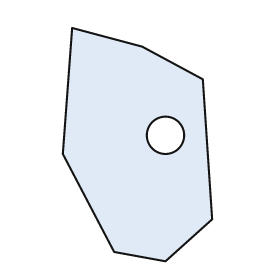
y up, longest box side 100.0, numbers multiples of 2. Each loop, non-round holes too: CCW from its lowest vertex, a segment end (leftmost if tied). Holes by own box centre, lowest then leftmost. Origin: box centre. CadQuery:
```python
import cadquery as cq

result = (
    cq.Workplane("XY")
    .moveTo(12.0, -50.0)
    .lineTo(32.0, -32.0)
    .lineTo(28.0, 28.0)
    .lineTo(2.0, 42.0)
    .lineTo(-28.0, 50.0)
    .lineTo(-32.0, -4.0)
    .lineTo(-10.0, -46.0)
    .close()
    .moveTo(12.0, 4.0)
    .circle(8.0)
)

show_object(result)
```